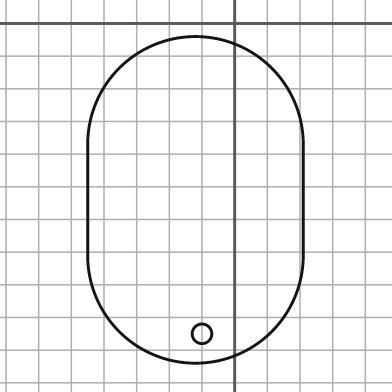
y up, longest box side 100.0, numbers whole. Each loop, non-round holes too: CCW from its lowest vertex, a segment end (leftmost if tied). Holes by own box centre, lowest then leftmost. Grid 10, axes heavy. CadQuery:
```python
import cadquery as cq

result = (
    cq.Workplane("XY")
    .moveTo(-45.0, -71.0)
    .threePointArc((-12.0, -104.0), (21.0, -71.0))
    .lineTo(21.0, -37.0)
    .threePointArc((-12.0, -4.0), (-45.0, -37.0))
    .close()
    .moveTo(-10.0, -95.0)
    .circle(3.0)
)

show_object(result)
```